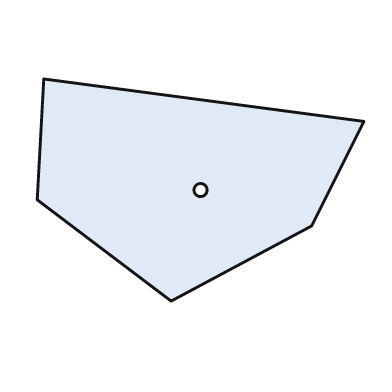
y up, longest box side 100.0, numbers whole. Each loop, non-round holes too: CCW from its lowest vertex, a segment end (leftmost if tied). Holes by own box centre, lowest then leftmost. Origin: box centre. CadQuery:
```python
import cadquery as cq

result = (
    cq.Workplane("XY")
    .moveTo(-9.0, -34.0)
    .lineTo(34.0, -11.0)
    .lineTo(50.0, 21.0)
    .lineTo(-48.0, 34.0)
    .lineTo(-50.0, -3.0)
    .close()
    .moveTo(0.0, 0.0)
    .circle(2.0)
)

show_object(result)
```